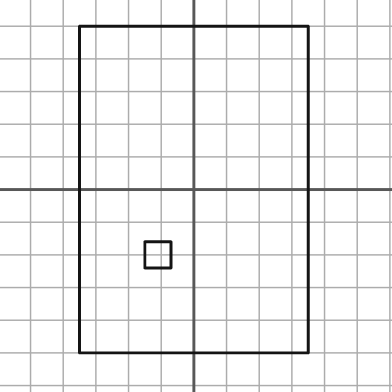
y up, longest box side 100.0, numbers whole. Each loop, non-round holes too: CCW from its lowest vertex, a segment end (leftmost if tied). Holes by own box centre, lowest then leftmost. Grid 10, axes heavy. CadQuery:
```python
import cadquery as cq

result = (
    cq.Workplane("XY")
    .moveTo(-35.0, -50.0)
    .lineTo(35.0, -50.0)
    .lineTo(35.0, 50.0)
    .lineTo(-35.0, 50.0)
    .close()
    .moveTo(-15.0, -24.0)
    .lineTo(-7.0, -24.0)
    .lineTo(-7.0, -16.0)
    .lineTo(-15.0, -16.0)
    .close()
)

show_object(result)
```